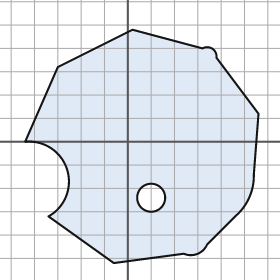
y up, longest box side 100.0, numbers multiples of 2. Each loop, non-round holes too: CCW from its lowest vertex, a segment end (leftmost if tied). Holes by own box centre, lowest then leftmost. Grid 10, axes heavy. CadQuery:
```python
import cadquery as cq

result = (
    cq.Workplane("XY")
    .moveTo(-6.0, -52.0)
    .lineTo(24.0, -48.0)
    .threePointArc((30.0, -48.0), (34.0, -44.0))
    .lineTo(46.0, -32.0)
    .threePointArc((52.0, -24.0), (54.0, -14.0))
    .lineTo(56.0, 12.0)
    .lineTo(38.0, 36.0)
    .threePointArc((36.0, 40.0), (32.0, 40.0))
    .lineTo(2.0, 48.0)
    .lineTo(-30.0, 32.0)
    .lineTo(-44.0, 0.0)
    .threePointArc((-26.0, -12.0), (-34.0, -32.0))
    .close()
    .moveTo(10.0, -24.0)
    .circle(6.0)
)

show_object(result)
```